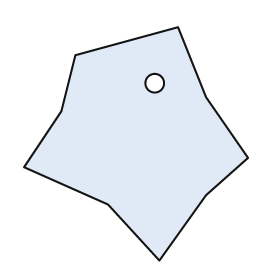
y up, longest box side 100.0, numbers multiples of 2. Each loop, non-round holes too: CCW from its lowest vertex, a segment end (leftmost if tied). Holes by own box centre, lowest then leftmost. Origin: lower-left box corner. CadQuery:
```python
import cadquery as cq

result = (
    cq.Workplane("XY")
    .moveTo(58.0, 0.0)
    .lineTo(78.0, 28.0)
    .lineTo(96.0, 44.0)
    .lineTo(78.0, 70.0)
    .lineTo(66.0, 100.0)
    .lineTo(22.0, 88.0)
    .lineTo(16.0, 64.0)
    .lineTo(0.0, 40.0)
    .lineTo(36.0, 24.0)
    .close()
    .moveTo(56.0, 76.0)
    .circle(4.0)
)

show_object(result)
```